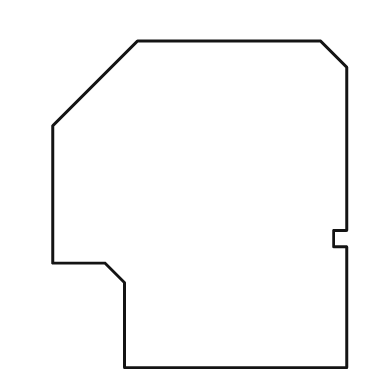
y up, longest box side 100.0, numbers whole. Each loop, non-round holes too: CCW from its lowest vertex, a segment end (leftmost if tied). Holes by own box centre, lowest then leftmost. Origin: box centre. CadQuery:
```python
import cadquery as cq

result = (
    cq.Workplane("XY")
    .moveTo(-23.0, -50.0)
    .lineTo(45.0, -50.0)
    .lineTo(45.0, -13.0)
    .lineTo(41.0, -13.0)
    .lineTo(41.0, -8.0)
    .lineTo(45.0, -8.0)
    .lineTo(45.0, 42.0)
    .lineTo(37.0, 50.0)
    .lineTo(-19.0, 50.0)
    .lineTo(-45.0, 24.0)
    .lineTo(-45.0, -18.0)
    .lineTo(-29.0, -18.0)
    .lineTo(-23.0, -24.0)
    .close()
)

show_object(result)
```